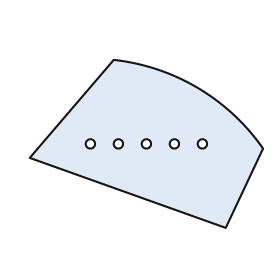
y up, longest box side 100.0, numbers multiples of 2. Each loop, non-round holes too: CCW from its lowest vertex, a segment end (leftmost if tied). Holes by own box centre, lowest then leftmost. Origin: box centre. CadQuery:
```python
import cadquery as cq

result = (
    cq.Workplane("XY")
    .moveTo(34.0, -36.0)
    .lineTo(50.0, -2.0)
    .threePointArc((22.0, 24.0), (-14.0, 36.0))
    .lineTo(-50.0, -6.0)
    .close()
    .moveTo(-24.0, 0.0)
    .circle(2.0)
    .moveTo(-12.0, 0.0)
    .circle(2.0)
    .moveTo(0.0, 0.0)
    .circle(2.0)
    .moveTo(12.0, 0.0)
    .circle(2.0)
    .moveTo(24.0, 0.0)
    .circle(2.0)
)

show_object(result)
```